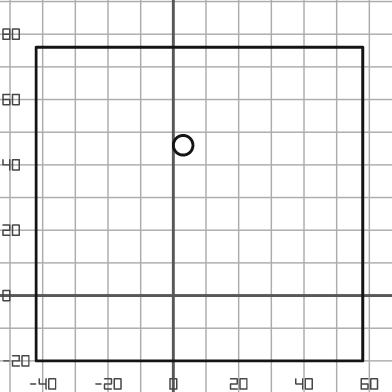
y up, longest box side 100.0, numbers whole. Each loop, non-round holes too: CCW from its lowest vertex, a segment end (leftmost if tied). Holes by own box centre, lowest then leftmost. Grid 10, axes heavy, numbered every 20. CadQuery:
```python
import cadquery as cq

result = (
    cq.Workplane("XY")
    .moveTo(-42.0, -20.0)
    .lineTo(58.0, -20.0)
    .lineTo(58.0, 76.0)
    .lineTo(-42.0, 76.0)
    .close()
    .moveTo(3.0, 46.0)
    .circle(3.0)
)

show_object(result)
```